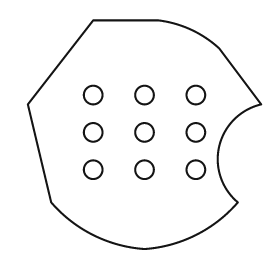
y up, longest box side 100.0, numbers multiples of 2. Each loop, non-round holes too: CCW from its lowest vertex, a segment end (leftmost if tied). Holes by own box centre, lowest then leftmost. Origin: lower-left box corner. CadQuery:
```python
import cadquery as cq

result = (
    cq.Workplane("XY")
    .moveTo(50.0, 0.0)
    .threePointArc((72.0, 6.0), (90.0, 20.0))
    .threePointArc((82.0, 44.0), (100.0, 62.0))
    .lineTo(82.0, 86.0)
    .threePointArc((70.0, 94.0), (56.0, 98.0))
    .lineTo(28.0, 98.0)
    .lineTo(0.0, 62.0)
    .lineTo(10.0, 20.0)
    .threePointArc((28.0, 6.0), (50.0, 0.0))
    .close()
    .moveTo(28.0, 34.0)
    .circle(4.0)
    .moveTo(50.0, 34.0)
    .circle(4.0)
    .moveTo(72.0, 34.0)
    .circle(4.0)
    .moveTo(28.0, 50.0)
    .circle(4.0)
    .moveTo(50.0, 50.0)
    .circle(4.0)
    .moveTo(72.0, 50.0)
    .circle(4.0)
    .moveTo(28.0, 66.0)
    .circle(4.0)
    .moveTo(50.0, 66.0)
    .circle(4.0)
    .moveTo(72.0, 66.0)
    .circle(4.0)
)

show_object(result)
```